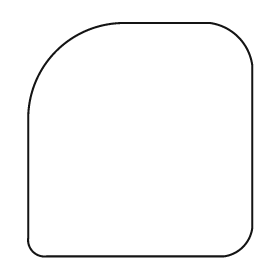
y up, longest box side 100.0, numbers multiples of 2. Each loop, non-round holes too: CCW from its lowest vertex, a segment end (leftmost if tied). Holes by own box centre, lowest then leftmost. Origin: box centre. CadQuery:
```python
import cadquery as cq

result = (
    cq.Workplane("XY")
    .moveTo(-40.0, -50.0)
    .lineTo(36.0, -50.0)
    .threePointArc((44.0, -46.0), (48.0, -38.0))
    .lineTo(48.0, 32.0)
    .threePointArc((42.0, 44.0), (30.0, 50.0))
    .lineTo(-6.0, 50.0)
    .threePointArc((-36.0, 38.0), (-48.0, 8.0))
    .lineTo(-48.0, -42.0)
    .threePointArc((-46.0, -48.0), (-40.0, -50.0))
    .close()
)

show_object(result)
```